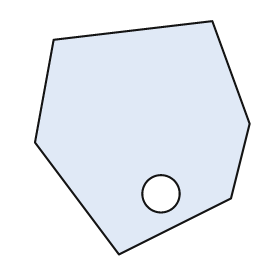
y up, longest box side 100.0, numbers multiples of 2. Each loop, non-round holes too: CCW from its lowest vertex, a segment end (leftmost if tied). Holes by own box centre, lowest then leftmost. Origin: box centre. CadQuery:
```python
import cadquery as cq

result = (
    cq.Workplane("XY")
    .moveTo(-10.0, -50.0)
    .lineTo(38.0, -26.0)
    .lineTo(46.0, 6.0)
    .lineTo(30.0, 50.0)
    .lineTo(-38.0, 42.0)
    .lineTo(-46.0, -2.0)
    .close()
    .moveTo(8.0, -24.0)
    .circle(8.0)
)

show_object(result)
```